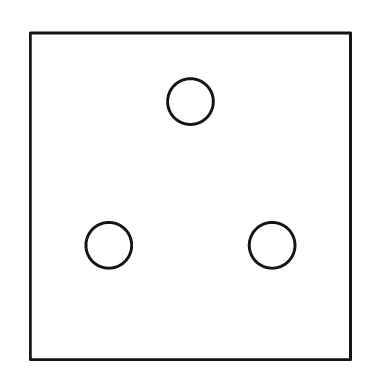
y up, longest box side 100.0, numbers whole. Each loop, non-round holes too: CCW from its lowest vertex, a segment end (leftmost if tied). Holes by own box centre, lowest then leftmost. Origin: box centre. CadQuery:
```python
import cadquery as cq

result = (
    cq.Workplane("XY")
    .moveTo(-49.0, -50.0)
    .lineTo(49.0, -50.0)
    .lineTo(49.0, 50.0)
    .lineTo(-49.0, 50.0)
    .close()
    .moveTo(-25.0, -15.0)
    .circle(7.0)
    .moveTo(25.0, -15.0)
    .circle(7.0)
    .moveTo(0.0, 29.0)
    .circle(7.0)
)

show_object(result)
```